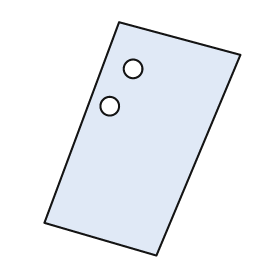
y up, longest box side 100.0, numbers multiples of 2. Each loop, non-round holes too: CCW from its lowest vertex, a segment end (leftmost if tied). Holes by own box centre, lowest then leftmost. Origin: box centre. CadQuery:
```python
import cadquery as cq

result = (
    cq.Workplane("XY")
    .moveTo(6.0, -50.0)
    .lineTo(42.0, 36.0)
    .lineTo(-10.0, 50.0)
    .lineTo(-42.0, -36.0)
    .close()
    .moveTo(-14.0, 14.0)
    .circle(4.0)
    .moveTo(-4.0, 30.0)
    .circle(4.0)
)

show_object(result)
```